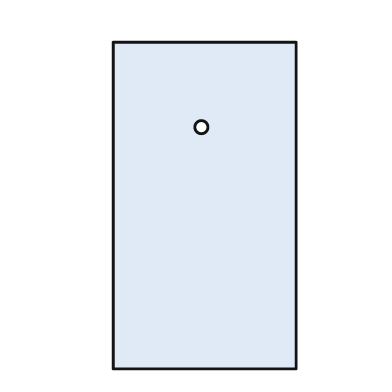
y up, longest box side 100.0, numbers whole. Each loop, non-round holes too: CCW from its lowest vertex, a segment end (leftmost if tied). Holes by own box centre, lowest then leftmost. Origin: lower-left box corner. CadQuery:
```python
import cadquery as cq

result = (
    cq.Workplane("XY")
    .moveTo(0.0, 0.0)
    .lineTo(56.0, 0.0)
    .lineTo(56.0, 100.0)
    .lineTo(0.0, 100.0)
    .close()
    .moveTo(27.0, 74.0)
    .circle(2.0)
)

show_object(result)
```